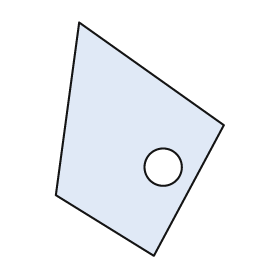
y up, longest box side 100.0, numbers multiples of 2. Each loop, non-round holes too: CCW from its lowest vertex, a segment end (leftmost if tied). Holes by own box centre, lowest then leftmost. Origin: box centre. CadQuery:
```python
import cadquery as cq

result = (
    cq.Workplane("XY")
    .moveTo(6.0, -50.0)
    .lineTo(36.0, 6.0)
    .lineTo(-26.0, 50.0)
    .lineTo(-36.0, -24.0)
    .close()
    .moveTo(10.0, -12.0)
    .circle(8.0)
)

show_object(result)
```